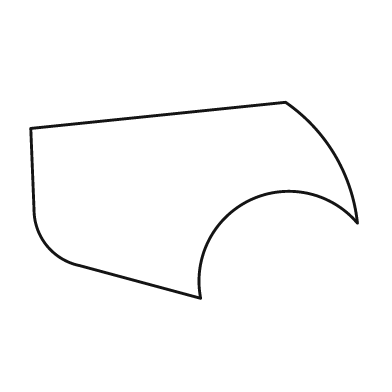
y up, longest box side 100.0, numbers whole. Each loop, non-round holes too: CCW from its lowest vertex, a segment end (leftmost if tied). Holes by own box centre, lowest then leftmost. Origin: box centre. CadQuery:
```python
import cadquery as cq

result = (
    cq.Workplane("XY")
    .moveTo(2.0, -30.0)
    .threePointArc((17.0, 0.0), (50.0, -7.0))
    .threePointArc((43.0, 14.0), (28.0, 30.0))
    .lineTo(-50.0, 22.0)
    .lineTo(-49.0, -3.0)
    .threePointArc((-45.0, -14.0), (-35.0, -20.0))
    .close()
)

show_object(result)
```